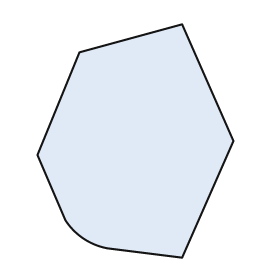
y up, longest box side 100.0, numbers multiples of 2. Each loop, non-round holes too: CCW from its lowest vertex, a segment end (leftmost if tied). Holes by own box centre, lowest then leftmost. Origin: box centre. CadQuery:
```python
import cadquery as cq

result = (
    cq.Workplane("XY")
    .moveTo(20.0, -50.0)
    .lineTo(42.0, 0.0)
    .lineTo(20.0, 50.0)
    .lineTo(-24.0, 38.0)
    .lineTo(-42.0, -6.0)
    .lineTo(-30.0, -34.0)
    .threePointArc((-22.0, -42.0), (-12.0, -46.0))
    .close()
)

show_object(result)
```